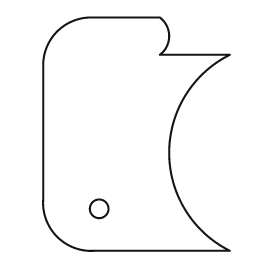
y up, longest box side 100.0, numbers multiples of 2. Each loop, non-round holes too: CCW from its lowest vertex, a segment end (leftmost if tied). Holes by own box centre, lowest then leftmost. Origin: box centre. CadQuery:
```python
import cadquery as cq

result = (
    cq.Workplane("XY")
    .moveTo(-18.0, -50.0)
    .lineTo(40.0, -50.0)
    .threePointArc((14.0, -8.0), (40.0, 34.0))
    .lineTo(10.0, 34.0)
    .threePointArc((14.0, 42.0), (10.0, 50.0))
    .lineTo(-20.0, 50.0)
    .threePointArc((-34.0, 44.0), (-40.0, 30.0))
    .lineTo(-40.0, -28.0)
    .threePointArc((-34.0, -44.0), (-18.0, -50.0))
    .close()
    .moveTo(-16.0, -32.0)
    .circle(4.0)
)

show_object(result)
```